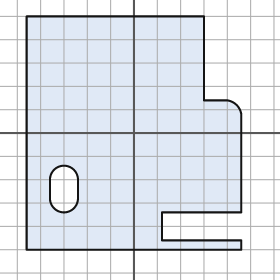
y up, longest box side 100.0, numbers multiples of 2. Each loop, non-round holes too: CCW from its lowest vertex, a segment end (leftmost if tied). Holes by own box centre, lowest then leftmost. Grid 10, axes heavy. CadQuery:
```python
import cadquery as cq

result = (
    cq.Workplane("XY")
    .moveTo(-46.0, -50.0)
    .lineTo(46.0, -50.0)
    .lineTo(46.0, -46.0)
    .lineTo(12.0, -46.0)
    .lineTo(12.0, -34.0)
    .lineTo(46.0, -34.0)
    .lineTo(46.0, 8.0)
    .threePointArc((44.0, 12.0), (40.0, 14.0))
    .lineTo(30.0, 14.0)
    .lineTo(30.0, 50.0)
    .lineTo(-46.0, 50.0)
    .close()
    .moveTo(-36.0, -28.0)
    .threePointArc((-30.0, -34.0), (-24.0, -28.0))
    .lineTo(-24.0, -20.0)
    .threePointArc((-30.0, -14.0), (-36.0, -20.0))
    .close()
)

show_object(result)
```